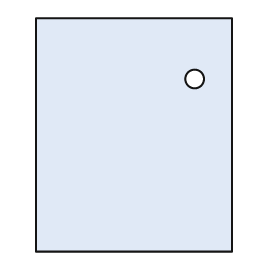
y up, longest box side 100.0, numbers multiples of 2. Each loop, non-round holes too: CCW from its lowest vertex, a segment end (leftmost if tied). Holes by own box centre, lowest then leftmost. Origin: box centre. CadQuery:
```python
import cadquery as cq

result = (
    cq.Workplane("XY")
    .moveTo(-42.0, -50.0)
    .lineTo(42.0, -50.0)
    .lineTo(42.0, 50.0)
    .lineTo(-42.0, 50.0)
    .close()
    .moveTo(26.0, 24.0)
    .circle(4.0)
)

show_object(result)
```